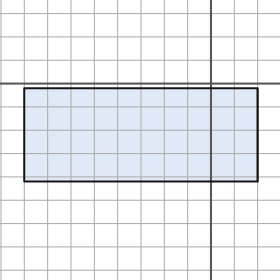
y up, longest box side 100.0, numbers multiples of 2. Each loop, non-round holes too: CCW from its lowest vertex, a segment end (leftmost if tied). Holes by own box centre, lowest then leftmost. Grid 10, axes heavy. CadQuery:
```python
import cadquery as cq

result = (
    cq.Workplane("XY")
    .moveTo(-80.0, -42.0)
    .lineTo(20.0, -42.0)
    .lineTo(20.0, -2.0)
    .lineTo(-80.0, -2.0)
    .close()
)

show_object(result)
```